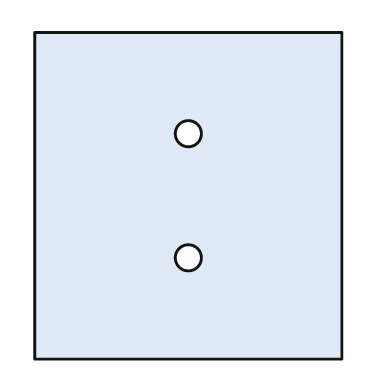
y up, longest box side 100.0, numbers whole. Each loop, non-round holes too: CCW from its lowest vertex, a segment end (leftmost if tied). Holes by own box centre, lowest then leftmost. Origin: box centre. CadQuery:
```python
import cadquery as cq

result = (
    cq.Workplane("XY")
    .moveTo(-47.0, -50.0)
    .lineTo(47.0, -50.0)
    .lineTo(47.0, 50.0)
    .lineTo(-47.0, 50.0)
    .close()
    .moveTo(0.0, -19.0)
    .circle(4.0)
    .moveTo(0.0, 19.0)
    .circle(4.0)
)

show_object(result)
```